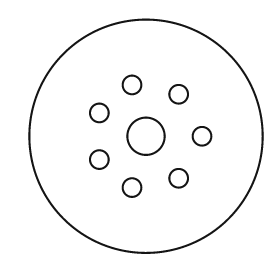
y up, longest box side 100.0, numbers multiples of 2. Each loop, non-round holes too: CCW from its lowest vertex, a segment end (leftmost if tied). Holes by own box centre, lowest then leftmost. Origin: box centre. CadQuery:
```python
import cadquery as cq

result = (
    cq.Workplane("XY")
    .moveTo(0.0, 0.0)
    .circle(50.0)
    .moveTo(-6.0, -22.0)
    .circle(4.0)
    .moveTo(14.0, -18.0)
    .circle(4.0)
    .moveTo(-20.0, -10.0)
    .circle(4.0)
    .moveTo(0.0, 0.0)
    .circle(8.0)
    .moveTo(24.0, 0.0)
    .circle(4.0)
    .moveTo(-20.0, 10.0)
    .circle(4.0)
    .moveTo(14.0, 18.0)
    .circle(4.0)
    .moveTo(-6.0, 22.0)
    .circle(4.0)
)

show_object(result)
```